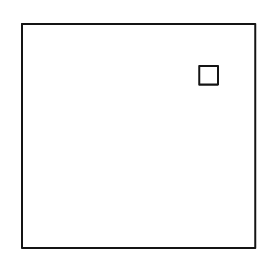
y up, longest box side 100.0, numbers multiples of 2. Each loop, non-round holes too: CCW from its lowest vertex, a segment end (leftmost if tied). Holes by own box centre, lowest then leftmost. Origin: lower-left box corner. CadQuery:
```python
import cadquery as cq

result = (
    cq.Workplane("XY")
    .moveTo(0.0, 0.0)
    .lineTo(100.0, 0.0)
    .lineTo(100.0, 96.0)
    .lineTo(0.0, 96.0)
    .close()
    .moveTo(76.0, 70.0)
    .lineTo(84.0, 70.0)
    .lineTo(84.0, 78.0)
    .lineTo(76.0, 78.0)
    .close()
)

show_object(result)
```